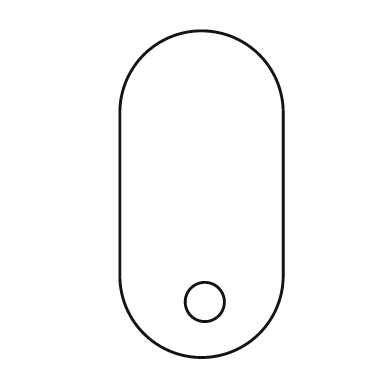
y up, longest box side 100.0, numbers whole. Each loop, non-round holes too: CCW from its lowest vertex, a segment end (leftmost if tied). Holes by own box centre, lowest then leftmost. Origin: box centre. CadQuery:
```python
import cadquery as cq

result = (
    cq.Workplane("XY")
    .moveTo(-25.0, -25.0)
    .threePointArc((0.0, -50.0), (25.0, -25.0))
    .lineTo(25.0, 25.0)
    .threePointArc((0.0, 50.0), (-25.0, 25.0))
    .close()
    .moveTo(1.0, -33.0)
    .circle(6.0)
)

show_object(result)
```